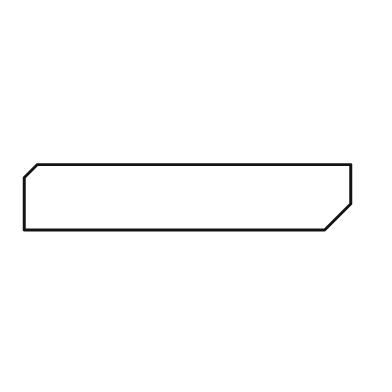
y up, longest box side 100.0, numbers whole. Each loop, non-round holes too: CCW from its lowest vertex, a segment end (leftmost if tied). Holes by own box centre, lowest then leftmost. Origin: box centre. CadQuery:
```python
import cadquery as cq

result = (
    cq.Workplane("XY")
    .moveTo(-50.0, -10.0)
    .lineTo(42.0, -10.0)
    .lineTo(50.0, -2.0)
    .lineTo(50.0, 10.0)
    .lineTo(-46.0, 10.0)
    .lineTo(-50.0, 6.0)
    .close()
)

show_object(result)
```